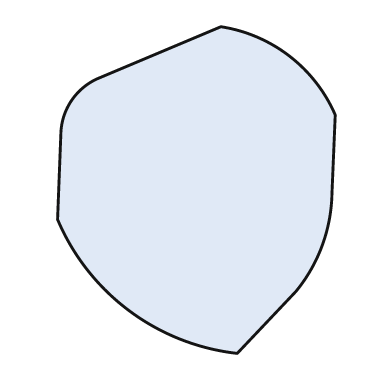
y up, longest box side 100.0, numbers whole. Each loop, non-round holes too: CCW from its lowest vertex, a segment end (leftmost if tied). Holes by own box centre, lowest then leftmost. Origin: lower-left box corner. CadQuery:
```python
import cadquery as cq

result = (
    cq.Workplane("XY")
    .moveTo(55.0, 0.0)
    .lineTo(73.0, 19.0)
    .threePointArc((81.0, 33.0), (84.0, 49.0))
    .lineTo(85.0, 73.0)
    .threePointArc((71.0, 91.0), (50.0, 100.0))
    .lineTo(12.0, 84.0)
    .threePointArc((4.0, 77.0), (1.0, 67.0))
    .lineTo(0.0, 41.0)
    .threePointArc((22.0, 13.0), (55.0, 0.0))
    .close()
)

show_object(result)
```